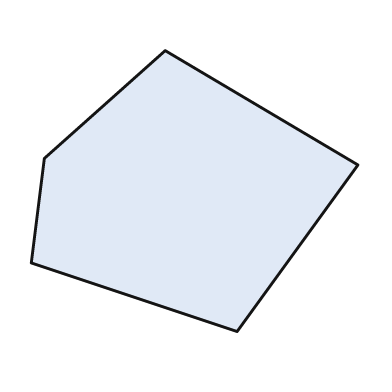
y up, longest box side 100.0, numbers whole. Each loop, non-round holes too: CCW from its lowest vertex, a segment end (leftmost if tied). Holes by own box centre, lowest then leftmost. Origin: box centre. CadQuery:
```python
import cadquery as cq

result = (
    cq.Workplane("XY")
    .moveTo(13.0, -43.0)
    .lineTo(50.0, 8.0)
    .lineTo(-9.0, 43.0)
    .lineTo(-46.0, 10.0)
    .lineTo(-50.0, -22.0)
    .close()
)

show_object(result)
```